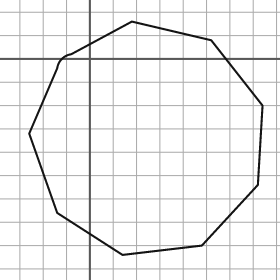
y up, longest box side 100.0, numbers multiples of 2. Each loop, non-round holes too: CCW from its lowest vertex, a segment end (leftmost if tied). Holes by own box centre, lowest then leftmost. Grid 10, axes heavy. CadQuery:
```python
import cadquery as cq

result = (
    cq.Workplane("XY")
    .moveTo(14.0, -84.0)
    .lineTo(48.0, -80.0)
    .lineTo(72.0, -54.0)
    .lineTo(74.0, -20.0)
    .lineTo(52.0, 8.0)
    .lineTo(18.0, 16.0)
    .lineTo(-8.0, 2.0)
    .threePointArc((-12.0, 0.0), (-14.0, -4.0))
    .lineTo(-26.0, -32.0)
    .lineTo(-14.0, -66.0)
    .close()
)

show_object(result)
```